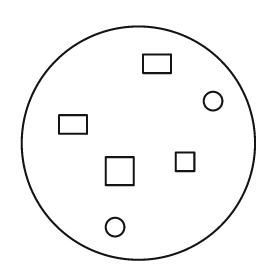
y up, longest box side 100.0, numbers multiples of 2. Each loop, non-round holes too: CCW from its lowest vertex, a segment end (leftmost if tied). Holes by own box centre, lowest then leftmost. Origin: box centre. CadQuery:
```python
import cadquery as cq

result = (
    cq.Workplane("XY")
    .moveTo(0.0, 0.0)
    .circle(50.0)
    .moveTo(-10.0, -36.0)
    .circle(4.0)
    .moveTo(-14.0, -18.0)
    .lineTo(-2.0, -18.0)
    .lineTo(-2.0, -6.0)
    .lineTo(-14.0, -6.0)
    .close()
    .moveTo(16.0, -12.0)
    .lineTo(24.0, -12.0)
    .lineTo(24.0, -4.0)
    .lineTo(16.0, -4.0)
    .close()
    .moveTo(-34.0, 4.0)
    .lineTo(-22.0, 4.0)
    .lineTo(-22.0, 12.0)
    .lineTo(-34.0, 12.0)
    .close()
    .moveTo(32.0, 18.0)
    .circle(4.0)
    .moveTo(2.0, 30.0)
    .lineTo(14.0, 30.0)
    .lineTo(14.0, 38.0)
    .lineTo(2.0, 38.0)
    .close()
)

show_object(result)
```